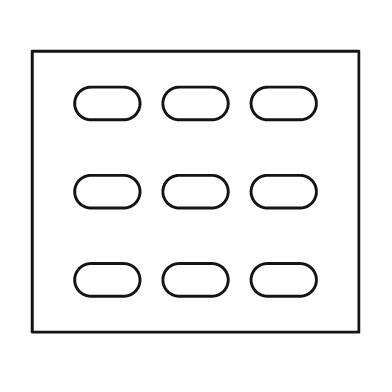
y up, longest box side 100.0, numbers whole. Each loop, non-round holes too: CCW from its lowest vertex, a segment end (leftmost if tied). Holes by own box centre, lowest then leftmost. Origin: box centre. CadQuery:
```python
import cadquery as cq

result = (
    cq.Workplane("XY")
    .moveTo(-50.0, -43.0)
    .lineTo(50.0, -43.0)
    .lineTo(50.0, 43.0)
    .lineTo(-50.0, 43.0)
    .close()
    .moveTo(-32.0, -32.0)
    .lineTo(-22.0, -32.0)
    .threePointArc((-17.0, -27.0), (-22.0, -22.0))
    .lineTo(-32.0, -22.0)
    .threePointArc((-37.0, -27.0), (-32.0, -32.0))
    .close()
    .moveTo(-5.0, -32.0)
    .lineTo(5.0, -32.0)
    .threePointArc((10.0, -27.0), (5.0, -22.0))
    .lineTo(-5.0, -22.0)
    .threePointArc((-10.0, -27.0), (-5.0, -32.0))
    .close()
    .moveTo(22.0, -32.0)
    .lineTo(32.0, -32.0)
    .threePointArc((37.0, -27.0), (32.0, -22.0))
    .lineTo(22.0, -22.0)
    .threePointArc((17.0, -27.0), (22.0, -32.0))
    .close()
    .moveTo(-32.0, -5.0)
    .lineTo(-22.0, -5.0)
    .threePointArc((-17.0, 0.0), (-22.0, 5.0))
    .lineTo(-32.0, 5.0)
    .threePointArc((-37.0, 0.0), (-32.0, -5.0))
    .close()
    .moveTo(-5.0, -5.0)
    .lineTo(5.0, -5.0)
    .threePointArc((10.0, 0.0), (5.0, 5.0))
    .lineTo(-5.0, 5.0)
    .threePointArc((-10.0, 0.0), (-5.0, -5.0))
    .close()
    .moveTo(22.0, -5.0)
    .lineTo(32.0, -5.0)
    .threePointArc((37.0, 0.0), (32.0, 5.0))
    .lineTo(22.0, 5.0)
    .threePointArc((17.0, 0.0), (22.0, -5.0))
    .close()
    .moveTo(-32.0, 22.0)
    .lineTo(-22.0, 22.0)
    .threePointArc((-17.0, 27.0), (-22.0, 32.0))
    .lineTo(-32.0, 32.0)
    .threePointArc((-37.0, 27.0), (-32.0, 22.0))
    .close()
    .moveTo(-5.0, 22.0)
    .lineTo(5.0, 22.0)
    .threePointArc((10.0, 27.0), (5.0, 32.0))
    .lineTo(-5.0, 32.0)
    .threePointArc((-10.0, 27.0), (-5.0, 22.0))
    .close()
    .moveTo(22.0, 22.0)
    .lineTo(32.0, 22.0)
    .threePointArc((37.0, 27.0), (32.0, 32.0))
    .lineTo(22.0, 32.0)
    .threePointArc((17.0, 27.0), (22.0, 22.0))
    .close()
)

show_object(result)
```